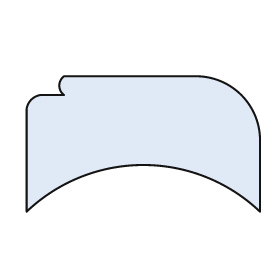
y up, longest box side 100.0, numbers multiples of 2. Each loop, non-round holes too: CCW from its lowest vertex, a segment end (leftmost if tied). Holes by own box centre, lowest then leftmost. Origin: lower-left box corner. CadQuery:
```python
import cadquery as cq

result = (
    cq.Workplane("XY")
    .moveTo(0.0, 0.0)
    .threePointArc((50.0, 20.0), (100.0, 0.0))
    .lineTo(100.0, 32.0)
    .threePointArc((92.0, 50.0), (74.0, 58.0))
    .lineTo(16.0, 58.0)
    .threePointArc((14.0, 54.0), (16.0, 50.0))
    .lineTo(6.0, 50.0)
    .threePointArc((2.0, 48.0), (0.0, 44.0))
    .close()
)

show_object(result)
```